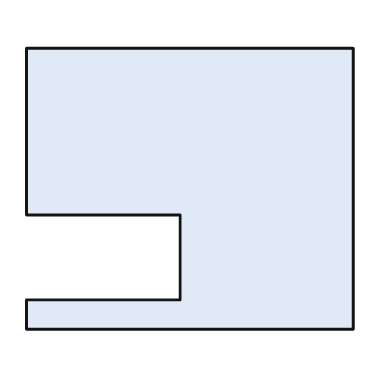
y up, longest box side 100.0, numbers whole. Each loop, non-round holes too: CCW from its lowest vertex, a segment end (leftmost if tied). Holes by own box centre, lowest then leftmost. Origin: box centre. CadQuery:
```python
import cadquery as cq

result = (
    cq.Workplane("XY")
    .moveTo(-50.0, -43.0)
    .lineTo(50.0, -43.0)
    .lineTo(50.0, 43.0)
    .lineTo(-50.0, 43.0)
    .lineTo(-50.0, -8.0)
    .lineTo(-3.0, -8.0)
    .lineTo(-3.0, -34.0)
    .lineTo(-50.0, -34.0)
    .close()
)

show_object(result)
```